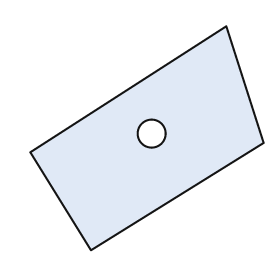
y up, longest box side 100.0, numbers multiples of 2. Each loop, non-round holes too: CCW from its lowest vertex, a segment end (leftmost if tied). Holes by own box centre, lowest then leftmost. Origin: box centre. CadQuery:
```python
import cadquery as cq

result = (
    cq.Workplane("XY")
    .moveTo(-24.0, -48.0)
    .lineTo(50.0, -2.0)
    .lineTo(34.0, 48.0)
    .lineTo(-50.0, -6.0)
    .close()
    .moveTo(2.0, 2.0)
    .circle(6.0)
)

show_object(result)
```